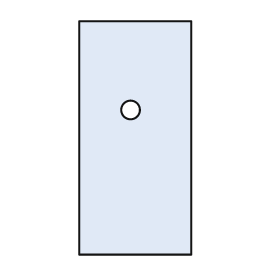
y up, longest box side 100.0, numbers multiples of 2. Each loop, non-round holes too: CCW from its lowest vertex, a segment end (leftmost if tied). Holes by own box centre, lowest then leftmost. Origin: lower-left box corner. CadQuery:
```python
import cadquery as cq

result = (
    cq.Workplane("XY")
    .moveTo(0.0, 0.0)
    .lineTo(48.0, 0.0)
    .lineTo(48.0, 100.0)
    .lineTo(0.0, 100.0)
    .close()
    .moveTo(22.0, 62.0)
    .circle(4.0)
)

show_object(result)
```